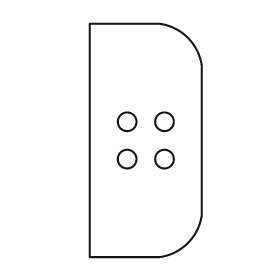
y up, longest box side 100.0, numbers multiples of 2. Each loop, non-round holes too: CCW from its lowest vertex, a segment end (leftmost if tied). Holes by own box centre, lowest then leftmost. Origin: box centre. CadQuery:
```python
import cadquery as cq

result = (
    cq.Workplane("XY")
    .moveTo(-24.0, -50.0)
    .lineTo(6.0, -50.0)
    .threePointArc((18.0, -44.0), (24.0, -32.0))
    .lineTo(24.0, 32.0)
    .threePointArc((18.0, 44.0), (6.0, 50.0))
    .lineTo(-24.0, 50.0)
    .close()
    .moveTo(-8.0, -8.0)
    .circle(4.0)
    .moveTo(8.0, -8.0)
    .circle(4.0)
    .moveTo(-8.0, 8.0)
    .circle(4.0)
    .moveTo(8.0, 8.0)
    .circle(4.0)
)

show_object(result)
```